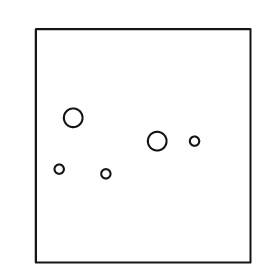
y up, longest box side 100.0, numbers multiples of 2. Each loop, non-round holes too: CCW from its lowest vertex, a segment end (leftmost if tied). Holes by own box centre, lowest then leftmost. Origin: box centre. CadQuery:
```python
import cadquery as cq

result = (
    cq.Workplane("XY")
    .moveTo(-46.0, -50.0)
    .lineTo(46.0, -50.0)
    .lineTo(46.0, 50.0)
    .lineTo(-46.0, 50.0)
    .close()
    .moveTo(-16.0, -12.0)
    .circle(2.0)
    .moveTo(-36.0, -10.0)
    .circle(2.0)
    .moveTo(6.0, 2.0)
    .circle(4.0)
    .moveTo(22.0, 2.0)
    .circle(2.0)
    .moveTo(-30.0, 12.0)
    .circle(4.0)
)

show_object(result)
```